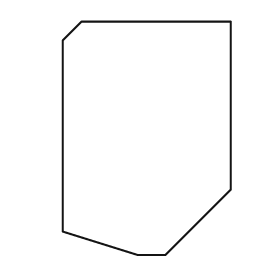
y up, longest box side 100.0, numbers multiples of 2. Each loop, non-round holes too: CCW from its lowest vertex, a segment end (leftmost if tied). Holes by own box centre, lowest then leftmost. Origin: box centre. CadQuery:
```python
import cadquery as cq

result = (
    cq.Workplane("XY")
    .moveTo(-4.0, -50.0)
    .lineTo(8.0, -50.0)
    .lineTo(36.0, -22.0)
    .lineTo(36.0, 50.0)
    .lineTo(-28.0, 50.0)
    .lineTo(-36.0, 42.0)
    .lineTo(-36.0, -40.0)
    .close()
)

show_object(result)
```